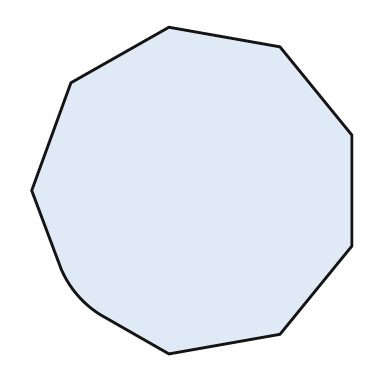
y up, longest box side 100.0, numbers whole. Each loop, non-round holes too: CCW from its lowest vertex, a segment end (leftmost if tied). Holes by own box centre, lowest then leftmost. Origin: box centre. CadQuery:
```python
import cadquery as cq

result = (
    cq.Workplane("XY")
    .moveTo(-7.0, -50.0)
    .lineTo(27.0, -44.0)
    .lineTo(49.0, -17.0)
    .lineTo(49.0, 17.0)
    .lineTo(27.0, 44.0)
    .lineTo(-7.0, 50.0)
    .lineTo(-37.0, 33.0)
    .lineTo(-49.0, 0.0)
    .lineTo(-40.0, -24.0)
    .threePointArc((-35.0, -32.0), (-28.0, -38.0))
    .close()
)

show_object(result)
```